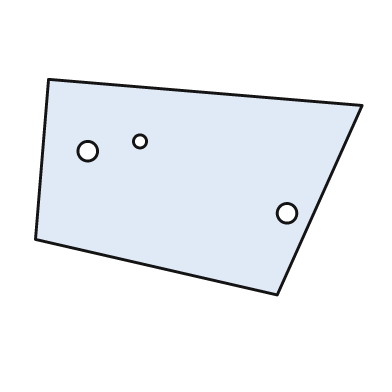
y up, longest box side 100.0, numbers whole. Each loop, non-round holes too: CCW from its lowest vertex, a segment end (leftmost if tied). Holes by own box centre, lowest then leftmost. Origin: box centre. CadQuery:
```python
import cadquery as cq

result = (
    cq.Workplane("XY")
    .moveTo(24.0, -33.0)
    .lineTo(50.0, 25.0)
    .lineTo(-46.0, 33.0)
    .lineTo(-50.0, -16.0)
    .close()
    .moveTo(27.0, -8.0)
    .circle(3.0)
    .moveTo(-34.0, 11.0)
    .circle(3.0)
    .moveTo(-18.0, 14.0)
    .circle(2.0)
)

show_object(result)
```